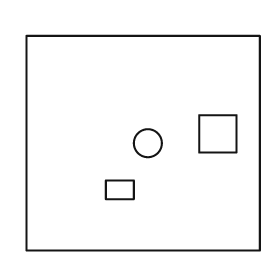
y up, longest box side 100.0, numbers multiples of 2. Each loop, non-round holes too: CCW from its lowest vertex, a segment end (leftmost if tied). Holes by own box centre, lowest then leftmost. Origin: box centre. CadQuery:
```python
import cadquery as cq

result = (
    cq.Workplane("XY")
    .moveTo(-50.0, -46.0)
    .lineTo(50.0, -46.0)
    .lineTo(50.0, 46.0)
    .lineTo(-50.0, 46.0)
    .close()
    .moveTo(-16.0, -24.0)
    .lineTo(-4.0, -24.0)
    .lineTo(-4.0, -16.0)
    .lineTo(-16.0, -16.0)
    .close()
    .moveTo(2.0, 0.0)
    .circle(6.0)
    .moveTo(24.0, -4.0)
    .lineTo(40.0, -4.0)
    .lineTo(40.0, 12.0)
    .lineTo(24.0, 12.0)
    .close()
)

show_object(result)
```